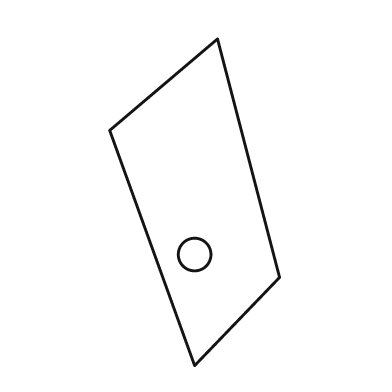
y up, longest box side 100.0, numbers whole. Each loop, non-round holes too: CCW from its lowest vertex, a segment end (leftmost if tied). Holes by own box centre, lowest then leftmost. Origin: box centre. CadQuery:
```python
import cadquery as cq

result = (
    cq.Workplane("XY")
    .moveTo(0.0, -50.0)
    .lineTo(26.0, -23.0)
    .lineTo(7.0, 50.0)
    .lineTo(-26.0, 22.0)
    .close()
    .moveTo(0.0, -16.0)
    .circle(5.0)
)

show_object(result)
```